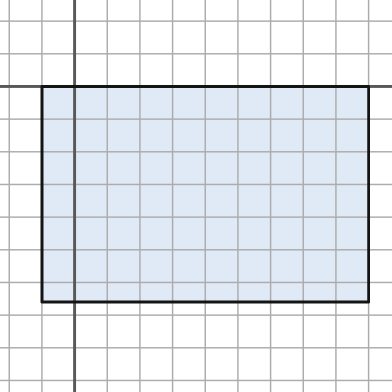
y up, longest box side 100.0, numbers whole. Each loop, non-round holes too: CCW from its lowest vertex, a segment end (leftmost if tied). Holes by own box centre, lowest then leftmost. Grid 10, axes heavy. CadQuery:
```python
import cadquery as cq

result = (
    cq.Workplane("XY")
    .moveTo(-10.0, -66.0)
    .lineTo(90.0, -66.0)
    .lineTo(90.0, 0.0)
    .lineTo(-10.0, 0.0)
    .close()
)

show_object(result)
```